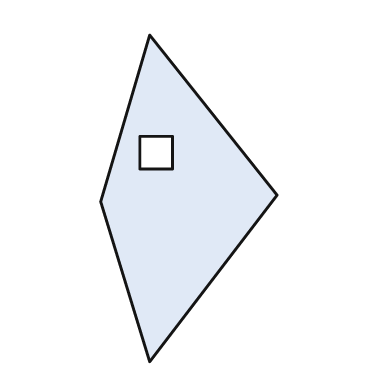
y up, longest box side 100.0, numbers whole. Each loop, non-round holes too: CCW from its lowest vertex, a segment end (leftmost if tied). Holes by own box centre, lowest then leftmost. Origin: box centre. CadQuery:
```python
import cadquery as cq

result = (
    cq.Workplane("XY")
    .moveTo(-12.0, -50.0)
    .lineTo(27.0, 1.0)
    .lineTo(-12.0, 50.0)
    .lineTo(-27.0, -1.0)
    .close()
    .moveTo(-15.0, 9.0)
    .lineTo(-5.0, 9.0)
    .lineTo(-5.0, 19.0)
    .lineTo(-15.0, 19.0)
    .close()
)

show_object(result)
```